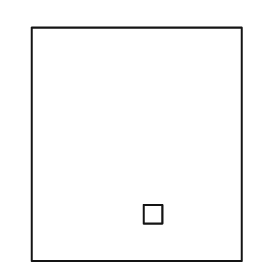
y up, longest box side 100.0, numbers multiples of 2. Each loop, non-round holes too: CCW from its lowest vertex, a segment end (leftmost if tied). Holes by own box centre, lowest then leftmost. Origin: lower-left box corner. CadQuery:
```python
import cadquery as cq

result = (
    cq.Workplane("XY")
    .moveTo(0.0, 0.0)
    .lineTo(90.0, 0.0)
    .lineTo(90.0, 100.0)
    .lineTo(0.0, 100.0)
    .close()
    .moveTo(48.0, 16.0)
    .lineTo(56.0, 16.0)
    .lineTo(56.0, 24.0)
    .lineTo(48.0, 24.0)
    .close()
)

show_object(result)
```